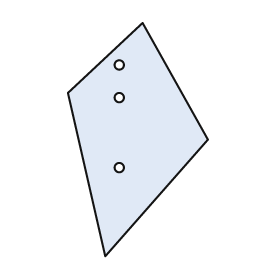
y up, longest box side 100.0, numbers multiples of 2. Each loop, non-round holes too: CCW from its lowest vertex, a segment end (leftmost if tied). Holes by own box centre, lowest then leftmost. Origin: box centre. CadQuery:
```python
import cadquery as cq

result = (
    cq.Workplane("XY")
    .moveTo(-14.0, -50.0)
    .lineTo(30.0, 0.0)
    .lineTo(2.0, 50.0)
    .lineTo(-30.0, 20.0)
    .close()
    .moveTo(-8.0, -12.0)
    .circle(2.0)
    .moveTo(-8.0, 18.0)
    .circle(2.0)
    .moveTo(-8.0, 32.0)
    .circle(2.0)
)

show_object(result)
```